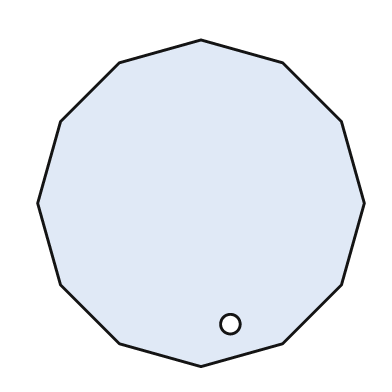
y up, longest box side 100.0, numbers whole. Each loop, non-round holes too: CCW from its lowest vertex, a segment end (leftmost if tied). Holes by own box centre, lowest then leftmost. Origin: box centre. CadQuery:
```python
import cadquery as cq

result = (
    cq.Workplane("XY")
    .moveTo(0.0, -50.0)
    .lineTo(25.0, -43.0)
    .lineTo(43.0, -25.0)
    .lineTo(50.0, 0.0)
    .lineTo(43.0, 25.0)
    .lineTo(25.0, 43.0)
    .lineTo(0.0, 50.0)
    .lineTo(-25.0, 43.0)
    .lineTo(-43.0, 25.0)
    .lineTo(-50.0, 0.0)
    .lineTo(-43.0, -25.0)
    .lineTo(-25.0, -43.0)
    .close()
    .moveTo(9.0, -37.0)
    .circle(3.0)
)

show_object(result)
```